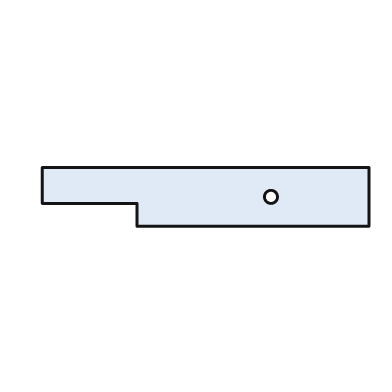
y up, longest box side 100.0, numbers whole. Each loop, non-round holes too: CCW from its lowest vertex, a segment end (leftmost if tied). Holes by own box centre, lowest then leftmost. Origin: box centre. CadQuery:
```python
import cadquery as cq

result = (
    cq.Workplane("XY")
    .moveTo(-21.0, -9.0)
    .lineTo(50.0, -9.0)
    .lineTo(50.0, 9.0)
    .lineTo(-50.0, 9.0)
    .lineTo(-50.0, -2.0)
    .lineTo(-21.0, -2.0)
    .close()
    .moveTo(20.0, 0.0)
    .circle(2.0)
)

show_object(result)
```